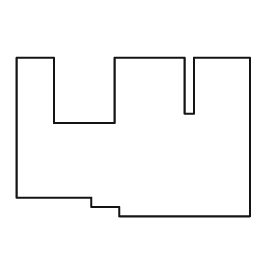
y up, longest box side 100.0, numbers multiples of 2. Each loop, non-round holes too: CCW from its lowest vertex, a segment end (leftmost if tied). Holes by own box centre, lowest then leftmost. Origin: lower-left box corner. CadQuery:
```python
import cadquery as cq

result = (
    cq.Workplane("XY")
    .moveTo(44.0, 0.0)
    .lineTo(100.0, 0.0)
    .lineTo(100.0, 68.0)
    .lineTo(76.0, 68.0)
    .lineTo(76.0, 44.0)
    .lineTo(72.0, 44.0)
    .lineTo(72.0, 68.0)
    .lineTo(42.0, 68.0)
    .lineTo(42.0, 40.0)
    .lineTo(16.0, 40.0)
    .lineTo(16.0, 68.0)
    .lineTo(0.0, 68.0)
    .lineTo(0.0, 8.0)
    .lineTo(32.0, 8.0)
    .lineTo(32.0, 4.0)
    .lineTo(44.0, 4.0)
    .close()
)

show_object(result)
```